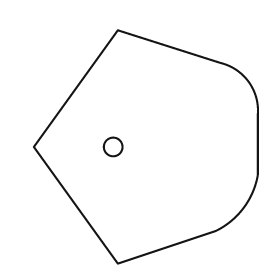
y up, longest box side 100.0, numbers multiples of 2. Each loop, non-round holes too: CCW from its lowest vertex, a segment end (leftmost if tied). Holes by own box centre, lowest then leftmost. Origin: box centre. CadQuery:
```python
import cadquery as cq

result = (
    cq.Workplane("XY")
    .moveTo(-12.0, -50.0)
    .lineTo(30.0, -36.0)
    .threePointArc((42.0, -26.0), (48.0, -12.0))
    .lineTo(48.0, 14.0)
    .threePointArc((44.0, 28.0), (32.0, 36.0))
    .lineTo(-12.0, 50.0)
    .lineTo(-48.0, 0.0)
    .close()
    .moveTo(-14.0, 0.0)
    .circle(4.0)
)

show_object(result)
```